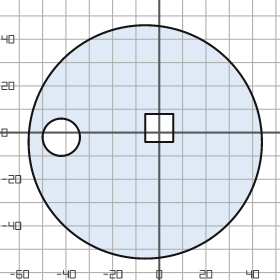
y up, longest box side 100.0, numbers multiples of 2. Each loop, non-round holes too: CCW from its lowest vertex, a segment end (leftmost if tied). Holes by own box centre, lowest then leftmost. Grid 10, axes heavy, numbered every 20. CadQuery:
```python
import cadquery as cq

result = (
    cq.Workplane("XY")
    .moveTo(-6.0, -4.0)
    .circle(50.0)
    .moveTo(-42.0, -2.0)
    .circle(8.0)
    .moveTo(-6.0, -4.0)
    .lineTo(6.0, -4.0)
    .lineTo(6.0, 8.0)
    .lineTo(-6.0, 8.0)
    .close()
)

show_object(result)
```